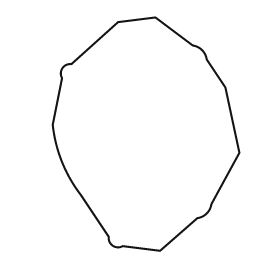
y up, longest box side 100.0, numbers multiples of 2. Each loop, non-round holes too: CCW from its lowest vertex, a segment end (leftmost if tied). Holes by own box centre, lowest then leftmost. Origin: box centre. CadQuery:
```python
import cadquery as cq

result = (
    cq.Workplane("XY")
    .moveTo(6.0, -50.0)
    .lineTo(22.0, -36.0)
    .threePointArc((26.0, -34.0), (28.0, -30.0))
    .lineTo(40.0, -8.0)
    .lineTo(34.0, 20.0)
    .lineTo(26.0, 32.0)
    .threePointArc((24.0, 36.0), (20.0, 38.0))
    .lineTo(4.0, 50.0)
    .lineTo(-12.0, 48.0)
    .lineTo(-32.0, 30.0)
    .threePointArc((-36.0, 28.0), (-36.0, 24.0))
    .lineTo(-40.0, 4.0)
    .threePointArc((-36.0, -12.0), (-28.0, -26.0))
    .lineTo(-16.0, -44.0)
    .threePointArc((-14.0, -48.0), (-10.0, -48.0))
    .close()
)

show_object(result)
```